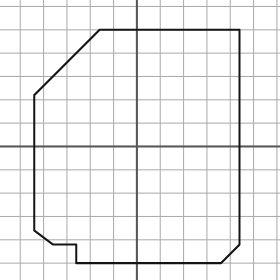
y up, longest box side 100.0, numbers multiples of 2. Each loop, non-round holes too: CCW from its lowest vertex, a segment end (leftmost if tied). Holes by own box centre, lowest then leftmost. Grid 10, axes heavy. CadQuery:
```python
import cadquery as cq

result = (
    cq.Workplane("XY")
    .moveTo(-26.0, -50.0)
    .lineTo(36.0, -50.0)
    .lineTo(44.0, -42.0)
    .lineTo(44.0, 50.0)
    .lineTo(-16.0, 50.0)
    .lineTo(-44.0, 22.0)
    .lineTo(-44.0, -36.0)
    .lineTo(-36.0, -42.0)
    .lineTo(-26.0, -42.0)
    .close()
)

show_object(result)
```